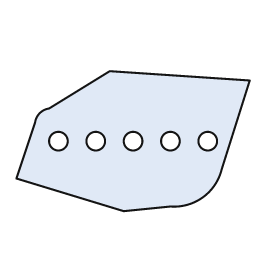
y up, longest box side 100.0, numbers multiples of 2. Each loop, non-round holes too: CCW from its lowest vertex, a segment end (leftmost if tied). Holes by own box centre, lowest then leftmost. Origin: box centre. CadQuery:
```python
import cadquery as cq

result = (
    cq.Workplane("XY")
    .moveTo(-4.0, -30.0)
    .lineTo(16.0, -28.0)
    .threePointArc((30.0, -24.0), (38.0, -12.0))
    .lineTo(50.0, 26.0)
    .lineTo(-10.0, 30.0)
    .lineTo(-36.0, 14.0)
    .threePointArc((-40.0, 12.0), (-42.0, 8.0))
    .lineTo(-50.0, -16.0)
    .close()
    .moveTo(-32.0, 0.0)
    .circle(4.0)
    .moveTo(-16.0, 0.0)
    .circle(4.0)
    .moveTo(0.0, 0.0)
    .circle(4.0)
    .moveTo(16.0, 0.0)
    .circle(4.0)
    .moveTo(32.0, 0.0)
    .circle(4.0)
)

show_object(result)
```